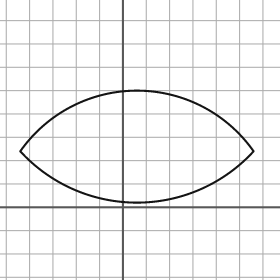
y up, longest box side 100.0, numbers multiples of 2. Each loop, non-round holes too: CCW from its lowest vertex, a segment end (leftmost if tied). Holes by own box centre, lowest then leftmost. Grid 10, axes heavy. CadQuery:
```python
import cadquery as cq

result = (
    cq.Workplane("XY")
    .moveTo(-44.0, 24.0)
    .threePointArc((6.0, 2.0), (56.0, 24.0))
    .threePointArc((6.0, 50.0), (-44.0, 24.0))
    .close()
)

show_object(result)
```